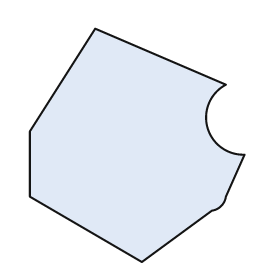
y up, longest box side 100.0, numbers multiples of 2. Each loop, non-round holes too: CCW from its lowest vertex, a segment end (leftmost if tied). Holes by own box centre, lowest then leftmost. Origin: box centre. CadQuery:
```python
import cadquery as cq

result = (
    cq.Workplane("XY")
    .moveTo(2.0, -50.0)
    .lineTo(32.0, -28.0)
    .threePointArc((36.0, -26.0), (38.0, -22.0))
    .lineTo(46.0, -4.0)
    .threePointArc((30.0, 8.0), (38.0, 26.0))
    .lineTo(-18.0, 50.0)
    .lineTo(-46.0, 6.0)
    .lineTo(-46.0, -22.0)
    .close()
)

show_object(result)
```